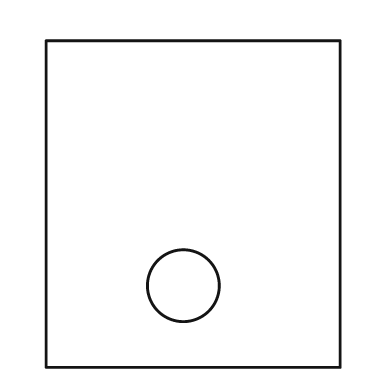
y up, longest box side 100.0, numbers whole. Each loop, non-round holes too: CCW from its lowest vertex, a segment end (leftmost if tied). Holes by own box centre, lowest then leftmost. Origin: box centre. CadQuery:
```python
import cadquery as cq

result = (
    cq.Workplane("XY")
    .moveTo(-45.0, -50.0)
    .lineTo(45.0, -50.0)
    .lineTo(45.0, 50.0)
    .lineTo(-45.0, 50.0)
    .close()
    .moveTo(-3.0, -25.0)
    .circle(11.0)
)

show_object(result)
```